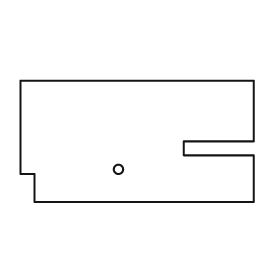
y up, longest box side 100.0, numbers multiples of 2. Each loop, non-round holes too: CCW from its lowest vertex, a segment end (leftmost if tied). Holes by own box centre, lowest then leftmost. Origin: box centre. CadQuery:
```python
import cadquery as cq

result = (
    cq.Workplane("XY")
    .moveTo(-44.0, -26.0)
    .lineTo(50.0, -26.0)
    .lineTo(50.0, -6.0)
    .lineTo(20.0, -6.0)
    .lineTo(20.0, 0.0)
    .lineTo(50.0, 0.0)
    .lineTo(50.0, 26.0)
    .lineTo(-50.0, 26.0)
    .lineTo(-50.0, -14.0)
    .lineTo(-44.0, -14.0)
    .close()
    .moveTo(-8.0, -12.0)
    .circle(2.0)
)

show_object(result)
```